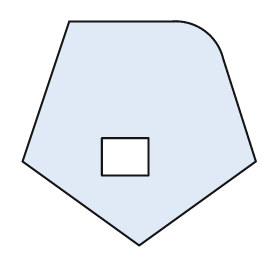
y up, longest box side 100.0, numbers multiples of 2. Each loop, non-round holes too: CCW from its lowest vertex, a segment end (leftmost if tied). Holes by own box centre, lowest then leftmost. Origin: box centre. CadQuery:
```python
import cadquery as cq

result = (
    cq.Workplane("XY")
    .moveTo(0.0, -48.0)
    .lineTo(50.0, -12.0)
    .lineTo(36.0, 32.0)
    .threePointArc((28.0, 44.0), (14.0, 48.0))
    .lineTo(-30.0, 48.0)
    .lineTo(-50.0, -12.0)
    .close()
    .moveTo(-16.0, -18.0)
    .lineTo(4.0, -18.0)
    .lineTo(4.0, -2.0)
    .lineTo(-16.0, -2.0)
    .close()
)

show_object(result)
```